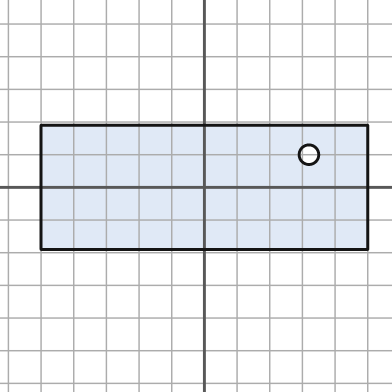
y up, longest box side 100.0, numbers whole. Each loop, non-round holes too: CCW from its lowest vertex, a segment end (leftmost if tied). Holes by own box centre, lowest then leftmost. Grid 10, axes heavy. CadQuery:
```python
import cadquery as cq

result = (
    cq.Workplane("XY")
    .moveTo(-50.0, -19.0)
    .lineTo(50.0, -19.0)
    .lineTo(50.0, 19.0)
    .lineTo(-50.0, 19.0)
    .close()
    .moveTo(32.0, 10.0)
    .circle(3.0)
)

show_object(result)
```